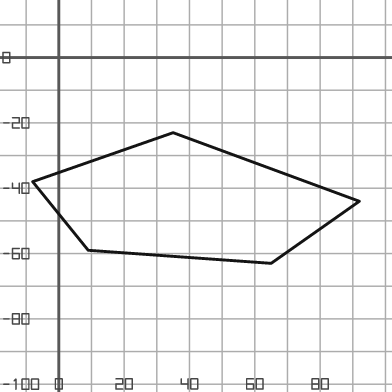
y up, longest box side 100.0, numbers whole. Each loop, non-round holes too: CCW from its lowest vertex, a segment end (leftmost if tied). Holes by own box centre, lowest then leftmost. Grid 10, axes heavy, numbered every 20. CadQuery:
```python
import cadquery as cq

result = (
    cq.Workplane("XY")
    .moveTo(65.0, -63.0)
    .lineTo(92.0, -44.0)
    .lineTo(35.0, -23.0)
    .lineTo(-8.0, -38.0)
    .lineTo(9.0, -59.0)
    .close()
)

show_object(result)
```